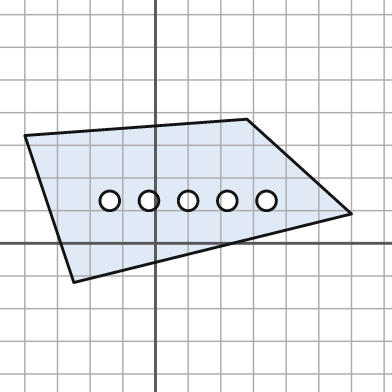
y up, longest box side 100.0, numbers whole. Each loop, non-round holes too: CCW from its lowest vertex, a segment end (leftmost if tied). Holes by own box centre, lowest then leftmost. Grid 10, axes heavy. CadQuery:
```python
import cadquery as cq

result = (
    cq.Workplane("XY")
    .moveTo(-25.0, -12.0)
    .lineTo(60.0, 9.0)
    .lineTo(28.0, 38.0)
    .lineTo(-40.0, 33.0)
    .close()
    .moveTo(-14.0, 13.0)
    .circle(3.0)
    .moveTo(-2.0, 13.0)
    .circle(3.0)
    .moveTo(10.0, 13.0)
    .circle(3.0)
    .moveTo(22.0, 13.0)
    .circle(3.0)
    .moveTo(34.0, 13.0)
    .circle(3.0)
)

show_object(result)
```